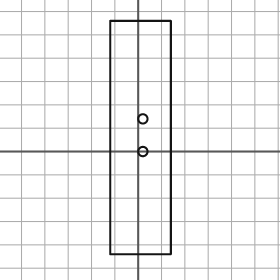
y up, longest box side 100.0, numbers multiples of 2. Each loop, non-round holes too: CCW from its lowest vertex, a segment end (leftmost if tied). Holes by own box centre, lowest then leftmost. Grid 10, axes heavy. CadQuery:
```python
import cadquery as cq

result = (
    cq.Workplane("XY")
    .moveTo(-12.0, -44.0)
    .lineTo(14.0, -44.0)
    .lineTo(14.0, 56.0)
    .lineTo(-12.0, 56.0)
    .close()
    .moveTo(2.0, 0.0)
    .circle(2.0)
    .moveTo(2.0, 14.0)
    .circle(2.0)
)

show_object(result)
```